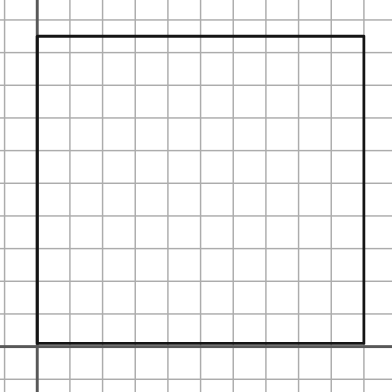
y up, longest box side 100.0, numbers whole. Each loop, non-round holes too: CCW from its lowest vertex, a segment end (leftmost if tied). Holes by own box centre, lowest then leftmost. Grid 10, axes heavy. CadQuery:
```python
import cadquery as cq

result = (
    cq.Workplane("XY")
    .moveTo(0.0, 1.0)
    .lineTo(100.0, 1.0)
    .lineTo(100.0, 95.0)
    .lineTo(0.0, 95.0)
    .close()
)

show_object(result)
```